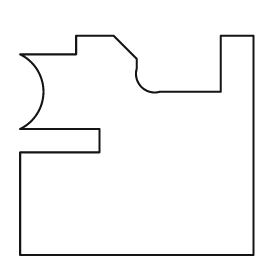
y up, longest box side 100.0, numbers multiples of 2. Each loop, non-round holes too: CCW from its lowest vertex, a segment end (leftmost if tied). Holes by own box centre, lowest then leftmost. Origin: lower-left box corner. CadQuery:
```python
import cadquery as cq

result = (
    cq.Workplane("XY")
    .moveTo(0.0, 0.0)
    .lineTo(100.0, 0.0)
    .lineTo(100.0, 94.0)
    .lineTo(86.0, 94.0)
    .lineTo(86.0, 70.0)
    .lineTo(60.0, 70.0)
    .threePointArc((52.0, 72.0), (50.0, 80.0))
    .lineTo(50.0, 84.0)
    .lineTo(40.0, 94.0)
    .lineTo(24.0, 94.0)
    .lineTo(24.0, 86.0)
    .lineTo(0.0, 86.0)
    .threePointArc((10.0, 70.0), (0.0, 54.0))
    .lineTo(34.0, 54.0)
    .lineTo(34.0, 44.0)
    .lineTo(0.0, 44.0)
    .close()
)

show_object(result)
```